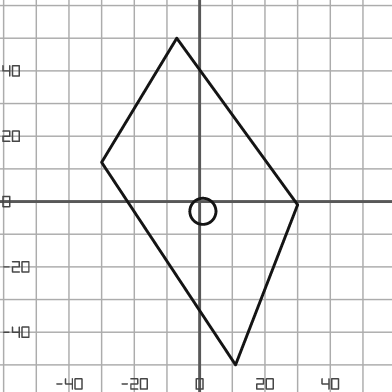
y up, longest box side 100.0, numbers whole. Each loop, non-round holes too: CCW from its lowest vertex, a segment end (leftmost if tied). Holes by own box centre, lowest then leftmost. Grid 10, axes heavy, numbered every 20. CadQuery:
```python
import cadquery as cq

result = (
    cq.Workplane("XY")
    .moveTo(11.0, -50.0)
    .lineTo(30.0, -1.0)
    .lineTo(-7.0, 50.0)
    .lineTo(-30.0, 12.0)
    .close()
    .moveTo(1.0, -3.0)
    .circle(4.0)
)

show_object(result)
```